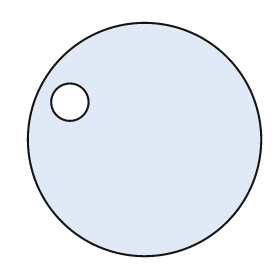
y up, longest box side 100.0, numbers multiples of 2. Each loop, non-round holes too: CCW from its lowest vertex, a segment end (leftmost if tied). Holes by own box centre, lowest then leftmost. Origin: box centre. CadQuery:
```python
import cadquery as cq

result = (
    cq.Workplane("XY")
    .moveTo(0.0, 0.0)
    .circle(50.0)
    .moveTo(-32.0, 16.0)
    .circle(8.0)
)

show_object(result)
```